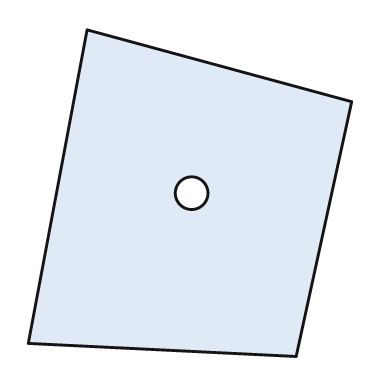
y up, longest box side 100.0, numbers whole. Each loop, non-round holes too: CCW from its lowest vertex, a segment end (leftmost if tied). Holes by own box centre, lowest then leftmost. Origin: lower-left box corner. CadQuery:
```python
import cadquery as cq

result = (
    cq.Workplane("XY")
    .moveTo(82.0, 0.0)
    .lineTo(99.0, 78.0)
    .lineTo(18.0, 100.0)
    .lineTo(0.0, 4.0)
    .close()
    .moveTo(50.0, 50.0)
    .circle(5.0)
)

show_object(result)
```